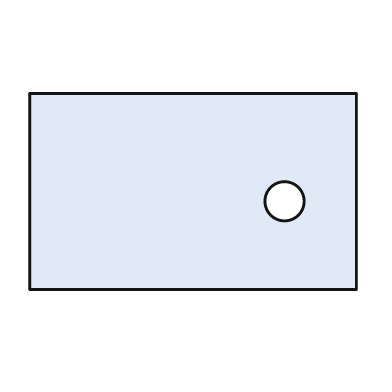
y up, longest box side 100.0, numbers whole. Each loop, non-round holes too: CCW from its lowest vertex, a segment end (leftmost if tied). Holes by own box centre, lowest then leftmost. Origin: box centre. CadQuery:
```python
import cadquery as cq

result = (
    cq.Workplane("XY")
    .moveTo(-50.0, -30.0)
    .lineTo(50.0, -30.0)
    .lineTo(50.0, 30.0)
    .lineTo(-50.0, 30.0)
    .close()
    .moveTo(28.0, -3.0)
    .circle(6.0)
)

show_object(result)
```